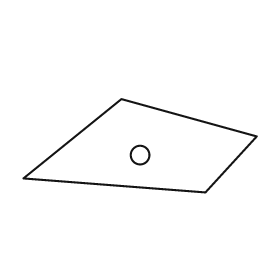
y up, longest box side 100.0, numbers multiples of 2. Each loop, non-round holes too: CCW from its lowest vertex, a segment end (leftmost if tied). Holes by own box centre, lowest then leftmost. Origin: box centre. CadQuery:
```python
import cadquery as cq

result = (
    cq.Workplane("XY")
    .moveTo(28.0, -20.0)
    .lineTo(50.0, 4.0)
    .lineTo(-8.0, 20.0)
    .lineTo(-50.0, -14.0)
    .close()
    .moveTo(0.0, -4.0)
    .circle(4.0)
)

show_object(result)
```